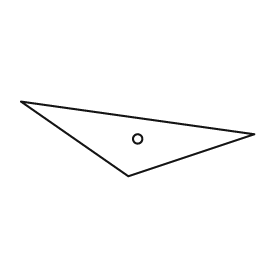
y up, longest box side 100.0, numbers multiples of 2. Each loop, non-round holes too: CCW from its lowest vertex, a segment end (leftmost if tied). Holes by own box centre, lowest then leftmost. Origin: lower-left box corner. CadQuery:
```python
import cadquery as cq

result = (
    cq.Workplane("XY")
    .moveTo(46.0, 0.0)
    .lineTo(100.0, 18.0)
    .lineTo(0.0, 32.0)
    .close()
    .moveTo(50.0, 16.0)
    .circle(2.0)
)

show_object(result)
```